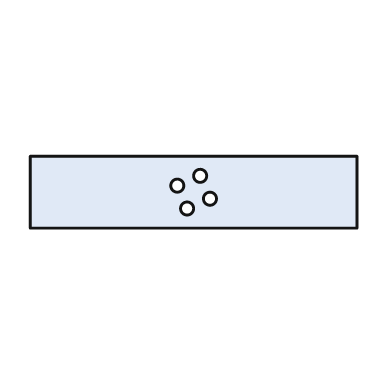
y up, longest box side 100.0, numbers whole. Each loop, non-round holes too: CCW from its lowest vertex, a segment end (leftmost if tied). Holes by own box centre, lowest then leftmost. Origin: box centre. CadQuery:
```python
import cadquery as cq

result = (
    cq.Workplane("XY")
    .moveTo(-50.0, -11.0)
    .lineTo(50.0, -11.0)
    .lineTo(50.0, 11.0)
    .lineTo(-50.0, 11.0)
    .close()
    .moveTo(-2.0, -5.0)
    .circle(2.0)
    .moveTo(5.0, -2.0)
    .circle(2.0)
    .moveTo(-5.0, 2.0)
    .circle(2.0)
    .moveTo(2.0, 5.0)
    .circle(2.0)
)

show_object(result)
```